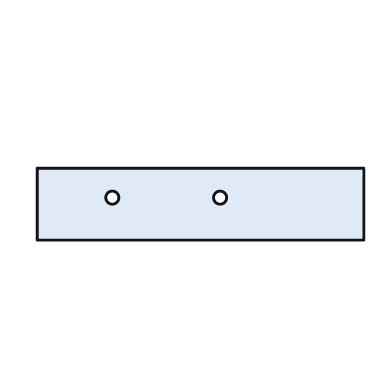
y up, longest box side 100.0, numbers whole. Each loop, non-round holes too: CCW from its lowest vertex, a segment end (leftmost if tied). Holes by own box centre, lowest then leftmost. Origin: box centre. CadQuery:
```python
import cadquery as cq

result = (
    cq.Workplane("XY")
    .moveTo(-50.0, -11.0)
    .lineTo(50.0, -11.0)
    .lineTo(50.0, 11.0)
    .lineTo(-50.0, 11.0)
    .close()
    .moveTo(-27.0, 2.0)
    .circle(2.0)
    .moveTo(6.0, 2.0)
    .circle(2.0)
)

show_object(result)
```